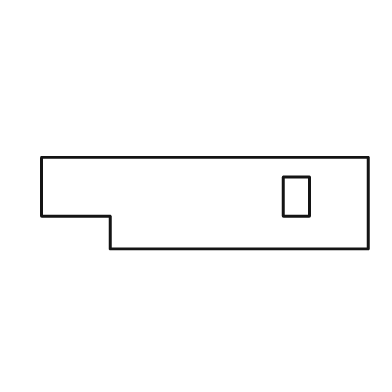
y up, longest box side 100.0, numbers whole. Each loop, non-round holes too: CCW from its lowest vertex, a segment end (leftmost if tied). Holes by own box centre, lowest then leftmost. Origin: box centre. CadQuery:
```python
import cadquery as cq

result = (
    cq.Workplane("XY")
    .moveTo(-29.0, -14.0)
    .lineTo(50.0, -14.0)
    .lineTo(50.0, 14.0)
    .lineTo(-50.0, 14.0)
    .lineTo(-50.0, -4.0)
    .lineTo(-29.0, -4.0)
    .close()
    .moveTo(24.0, -4.0)
    .lineTo(32.0, -4.0)
    .lineTo(32.0, 8.0)
    .lineTo(24.0, 8.0)
    .close()
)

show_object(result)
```